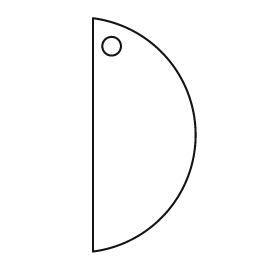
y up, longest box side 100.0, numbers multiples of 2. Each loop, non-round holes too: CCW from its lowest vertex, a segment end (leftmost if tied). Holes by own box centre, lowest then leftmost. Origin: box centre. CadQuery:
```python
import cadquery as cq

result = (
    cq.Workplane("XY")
    .moveTo(-22.0, -50.0)
    .threePointArc((22.0, 0.0), (-22.0, 50.0))
    .close()
    .moveTo(-14.0, 38.0)
    .circle(4.0)
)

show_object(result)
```